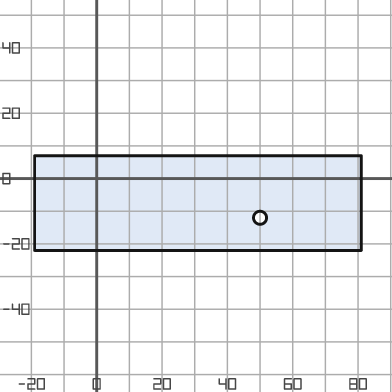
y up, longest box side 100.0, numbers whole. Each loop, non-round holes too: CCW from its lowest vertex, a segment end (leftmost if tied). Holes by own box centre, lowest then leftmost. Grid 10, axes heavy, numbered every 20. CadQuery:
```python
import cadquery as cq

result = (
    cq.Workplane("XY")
    .moveTo(-19.0, -22.0)
    .lineTo(81.0, -22.0)
    .lineTo(81.0, 7.0)
    .lineTo(-19.0, 7.0)
    .close()
    .moveTo(50.0, -12.0)
    .circle(2.0)
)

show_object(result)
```